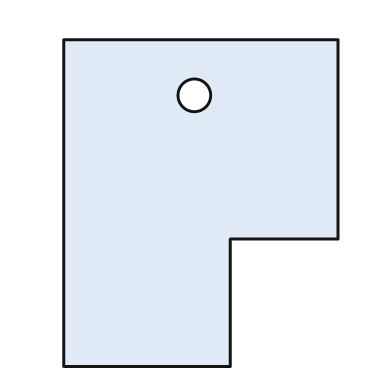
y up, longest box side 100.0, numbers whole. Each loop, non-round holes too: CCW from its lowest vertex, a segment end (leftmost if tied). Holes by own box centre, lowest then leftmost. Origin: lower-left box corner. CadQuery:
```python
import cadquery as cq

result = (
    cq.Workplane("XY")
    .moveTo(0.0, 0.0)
    .lineTo(51.0, 0.0)
    .lineTo(51.0, 39.0)
    .lineTo(84.0, 39.0)
    .lineTo(84.0, 100.0)
    .lineTo(0.0, 100.0)
    .close()
    .moveTo(40.0, 83.0)
    .circle(5.0)
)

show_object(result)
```